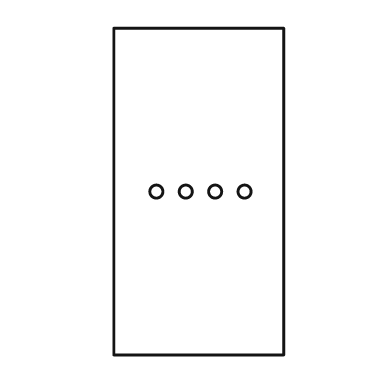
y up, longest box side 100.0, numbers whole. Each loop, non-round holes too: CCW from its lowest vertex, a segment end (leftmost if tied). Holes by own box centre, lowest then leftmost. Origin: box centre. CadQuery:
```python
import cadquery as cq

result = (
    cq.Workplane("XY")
    .moveTo(-26.0, -50.0)
    .lineTo(26.0, -50.0)
    .lineTo(26.0, 50.0)
    .lineTo(-26.0, 50.0)
    .close()
    .moveTo(-13.0, 0.0)
    .circle(2.0)
    .moveTo(-4.0, 0.0)
    .circle(2.0)
    .moveTo(5.0, 0.0)
    .circle(2.0)
    .moveTo(14.0, 0.0)
    .circle(2.0)
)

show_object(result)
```